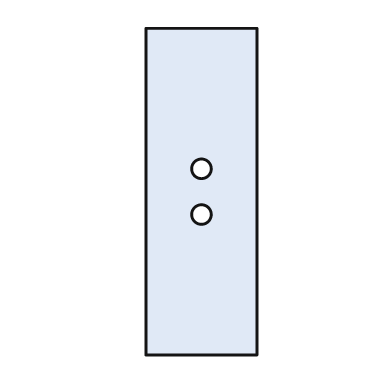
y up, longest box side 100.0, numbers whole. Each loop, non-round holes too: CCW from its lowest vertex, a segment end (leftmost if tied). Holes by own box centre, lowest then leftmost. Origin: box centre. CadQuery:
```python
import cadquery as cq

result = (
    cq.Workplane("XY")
    .moveTo(-17.0, -50.0)
    .lineTo(17.0, -50.0)
    .lineTo(17.0, 50.0)
    .lineTo(-17.0, 50.0)
    .close()
    .moveTo(0.0, -7.0)
    .circle(3.0)
    .moveTo(0.0, 7.0)
    .circle(3.0)
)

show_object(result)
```